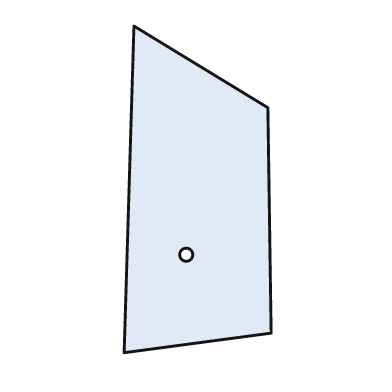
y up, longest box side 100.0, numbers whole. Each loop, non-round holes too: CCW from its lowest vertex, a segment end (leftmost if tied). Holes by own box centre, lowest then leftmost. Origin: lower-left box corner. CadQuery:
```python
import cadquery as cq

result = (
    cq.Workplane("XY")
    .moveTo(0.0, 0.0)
    .lineTo(45.0, 6.0)
    .lineTo(44.0, 75.0)
    .lineTo(3.0, 100.0)
    .close()
    .moveTo(19.0, 30.0)
    .circle(2.0)
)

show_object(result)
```